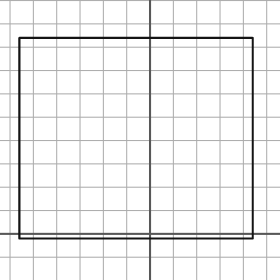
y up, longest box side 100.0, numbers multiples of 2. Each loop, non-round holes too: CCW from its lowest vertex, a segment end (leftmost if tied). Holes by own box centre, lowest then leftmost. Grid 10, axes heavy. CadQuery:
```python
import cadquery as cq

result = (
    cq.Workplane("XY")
    .moveTo(-56.0, -2.0)
    .lineTo(44.0, -2.0)
    .lineTo(44.0, 84.0)
    .lineTo(-56.0, 84.0)
    .close()
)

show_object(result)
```